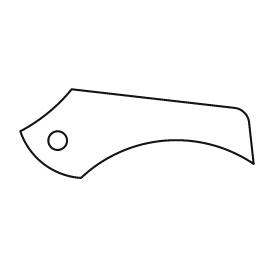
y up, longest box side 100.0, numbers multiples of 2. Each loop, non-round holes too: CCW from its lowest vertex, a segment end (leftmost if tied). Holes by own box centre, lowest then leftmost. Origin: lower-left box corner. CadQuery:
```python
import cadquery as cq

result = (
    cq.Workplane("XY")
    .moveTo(26.0, 0.0)
    .threePointArc((62.0, 16.0), (100.0, 6.0))
    .lineTo(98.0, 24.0)
    .threePointArc((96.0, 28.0), (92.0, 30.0))
    .lineTo(22.0, 38.0)
    .threePointArc((12.0, 28.0), (0.0, 20.0))
    .threePointArc((10.0, 6.0), (26.0, 0.0))
    .close()
    .moveTo(16.0, 16.0)
    .circle(4.0)
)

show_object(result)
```